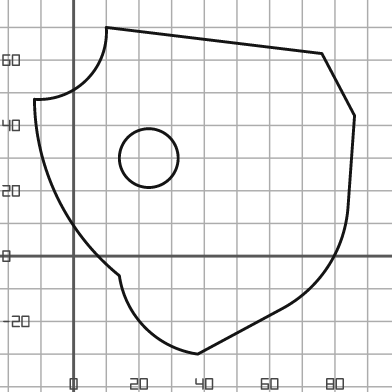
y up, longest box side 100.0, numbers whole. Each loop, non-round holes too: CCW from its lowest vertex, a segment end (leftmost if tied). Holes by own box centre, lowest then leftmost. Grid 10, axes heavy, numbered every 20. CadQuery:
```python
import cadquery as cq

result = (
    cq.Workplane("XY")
    .moveTo(38.0, -30.0)
    .lineTo(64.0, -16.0)
    .threePointArc((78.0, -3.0), (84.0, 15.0))
    .lineTo(86.0, 43.0)
    .lineTo(76.0, 62.0)
    .lineTo(10.0, 70.0)
    .threePointArc((4.0, 54.0), (-12.0, 48.0))
    .threePointArc((-5.0, 18.0), (14.0, -6.0))
    .threePointArc((22.0, -22.0), (38.0, -30.0))
    .close()
    .moveTo(23.0, 30.0)
    .circle(9.0)
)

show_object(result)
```